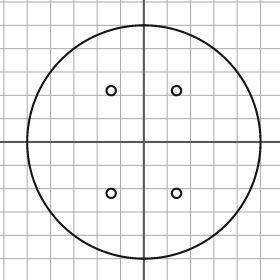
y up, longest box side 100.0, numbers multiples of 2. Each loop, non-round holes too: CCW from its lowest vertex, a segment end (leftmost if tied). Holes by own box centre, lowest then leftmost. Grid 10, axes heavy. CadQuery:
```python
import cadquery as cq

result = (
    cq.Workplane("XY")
    .moveTo(0.0, 0.0)
    .circle(50.0)
    .moveTo(-14.0, -22.0)
    .circle(2.0)
    .moveTo(14.0, -22.0)
    .circle(2.0)
    .moveTo(-14.0, 22.0)
    .circle(2.0)
    .moveTo(14.0, 22.0)
    .circle(2.0)
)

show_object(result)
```